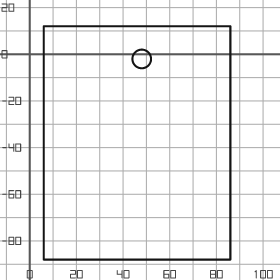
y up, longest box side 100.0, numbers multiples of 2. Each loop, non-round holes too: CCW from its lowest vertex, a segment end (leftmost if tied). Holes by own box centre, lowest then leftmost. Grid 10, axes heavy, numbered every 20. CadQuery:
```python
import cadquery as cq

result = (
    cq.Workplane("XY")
    .moveTo(6.0, -88.0)
    .lineTo(86.0, -88.0)
    .lineTo(86.0, 12.0)
    .lineTo(6.0, 12.0)
    .close()
    .moveTo(48.0, -2.0)
    .circle(4.0)
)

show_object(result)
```